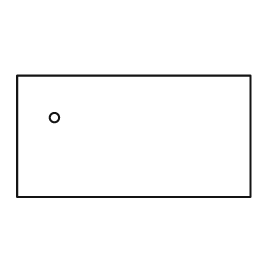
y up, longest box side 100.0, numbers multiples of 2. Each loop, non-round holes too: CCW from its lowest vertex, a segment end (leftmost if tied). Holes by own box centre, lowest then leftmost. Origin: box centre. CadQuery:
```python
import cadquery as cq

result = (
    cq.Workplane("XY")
    .moveTo(-50.0, -26.0)
    .lineTo(50.0, -26.0)
    .lineTo(50.0, 26.0)
    .lineTo(-50.0, 26.0)
    .close()
    .moveTo(-34.0, 8.0)
    .circle(2.0)
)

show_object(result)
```